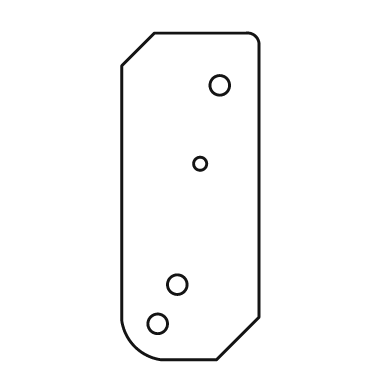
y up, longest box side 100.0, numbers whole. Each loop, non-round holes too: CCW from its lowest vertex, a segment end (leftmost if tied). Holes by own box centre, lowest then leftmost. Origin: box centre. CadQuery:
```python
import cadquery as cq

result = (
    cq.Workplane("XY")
    .moveTo(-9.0, -50.0)
    .lineTo(8.0, -50.0)
    .lineTo(21.0, -37.0)
    .lineTo(21.0, 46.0)
    .threePointArc((20.0, 49.0), (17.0, 50.0))
    .lineTo(-11.0, 50.0)
    .lineTo(-21.0, 40.0)
    .lineTo(-21.0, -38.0)
    .threePointArc((-17.0, -46.0), (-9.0, -50.0))
    .close()
    .moveTo(-10.0, -39.0)
    .circle(3.0)
    .moveTo(-4.0, -27.0)
    .circle(3.0)
    .moveTo(3.0, 10.0)
    .circle(2.0)
    .moveTo(9.0, 34.0)
    .circle(3.0)
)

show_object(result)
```